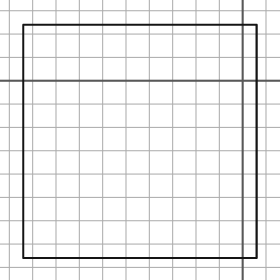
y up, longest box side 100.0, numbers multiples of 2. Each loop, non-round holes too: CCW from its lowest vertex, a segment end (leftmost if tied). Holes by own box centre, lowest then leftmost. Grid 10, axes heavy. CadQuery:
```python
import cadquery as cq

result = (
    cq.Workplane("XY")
    .moveTo(-94.0, -76.0)
    .lineTo(6.0, -76.0)
    .lineTo(6.0, 24.0)
    .lineTo(-94.0, 24.0)
    .close()
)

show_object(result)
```